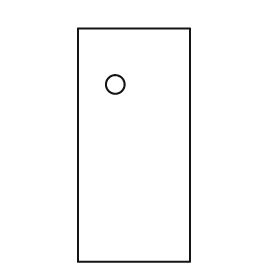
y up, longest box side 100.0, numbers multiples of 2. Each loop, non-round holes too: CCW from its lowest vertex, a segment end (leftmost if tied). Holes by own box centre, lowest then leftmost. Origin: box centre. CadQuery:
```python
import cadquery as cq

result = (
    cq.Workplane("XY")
    .moveTo(-24.0, -50.0)
    .lineTo(24.0, -50.0)
    .lineTo(24.0, 50.0)
    .lineTo(-24.0, 50.0)
    .close()
    .moveTo(-8.0, 26.0)
    .circle(4.0)
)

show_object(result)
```